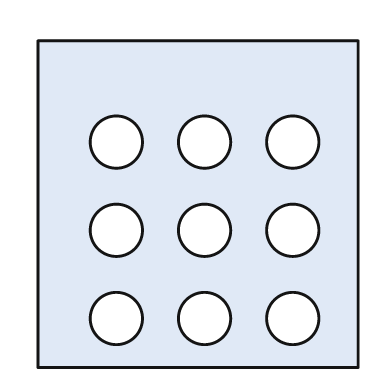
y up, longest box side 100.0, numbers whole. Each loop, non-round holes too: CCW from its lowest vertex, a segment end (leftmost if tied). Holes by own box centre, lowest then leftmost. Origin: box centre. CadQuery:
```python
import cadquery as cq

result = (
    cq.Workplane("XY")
    .moveTo(-49.0, -50.0)
    .lineTo(49.0, -50.0)
    .lineTo(49.0, 50.0)
    .lineTo(-49.0, 50.0)
    .close()
    .moveTo(-25.0, -35.0)
    .circle(8.0)
    .moveTo(2.0, -35.0)
    .circle(8.0)
    .moveTo(29.0, -35.0)
    .circle(8.0)
    .moveTo(-25.0, -8.0)
    .circle(8.0)
    .moveTo(2.0, -8.0)
    .circle(8.0)
    .moveTo(29.0, -8.0)
    .circle(8.0)
    .moveTo(-25.0, 19.0)
    .circle(8.0)
    .moveTo(2.0, 19.0)
    .circle(8.0)
    .moveTo(29.0, 19.0)
    .circle(8.0)
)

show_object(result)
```